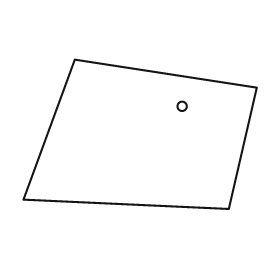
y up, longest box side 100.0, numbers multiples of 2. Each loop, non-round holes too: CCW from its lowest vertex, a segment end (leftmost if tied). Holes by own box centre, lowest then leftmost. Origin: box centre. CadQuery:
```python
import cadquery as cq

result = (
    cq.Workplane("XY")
    .moveTo(38.0, -32.0)
    .lineTo(50.0, 20.0)
    .lineTo(-28.0, 32.0)
    .lineTo(-50.0, -28.0)
    .close()
    .moveTo(18.0, 12.0)
    .circle(2.0)
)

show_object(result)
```